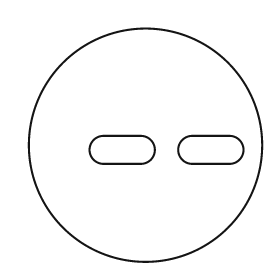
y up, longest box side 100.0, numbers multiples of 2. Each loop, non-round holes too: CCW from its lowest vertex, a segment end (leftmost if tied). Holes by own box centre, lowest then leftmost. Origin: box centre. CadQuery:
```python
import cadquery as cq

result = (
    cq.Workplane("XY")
    .moveTo(0.0, 0.0)
    .circle(50.0)
    .moveTo(-18.0, -8.0)
    .lineTo(-2.0, -8.0)
    .threePointArc((4.0, -2.0), (-2.0, 4.0))
    .lineTo(-18.0, 4.0)
    .threePointArc((-24.0, -2.0), (-18.0, -8.0))
    .close()
    .moveTo(20.0, -8.0)
    .lineTo(36.0, -8.0)
    .threePointArc((42.0, -2.0), (36.0, 4.0))
    .lineTo(20.0, 4.0)
    .threePointArc((14.0, -2.0), (20.0, -8.0))
    .close()
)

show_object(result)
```